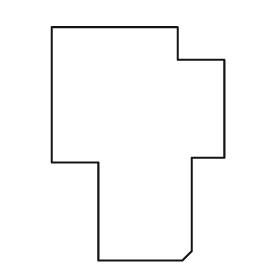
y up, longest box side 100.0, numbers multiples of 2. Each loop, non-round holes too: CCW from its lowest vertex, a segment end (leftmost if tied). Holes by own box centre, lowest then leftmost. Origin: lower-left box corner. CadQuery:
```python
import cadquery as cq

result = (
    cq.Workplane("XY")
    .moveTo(20.0, 0.0)
    .lineTo(56.0, 0.0)
    .lineTo(60.0, 4.0)
    .lineTo(60.0, 44.0)
    .lineTo(74.0, 44.0)
    .lineTo(74.0, 86.0)
    .lineTo(54.0, 86.0)
    .lineTo(54.0, 100.0)
    .lineTo(0.0, 100.0)
    .lineTo(0.0, 42.0)
    .lineTo(20.0, 42.0)
    .close()
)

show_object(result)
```